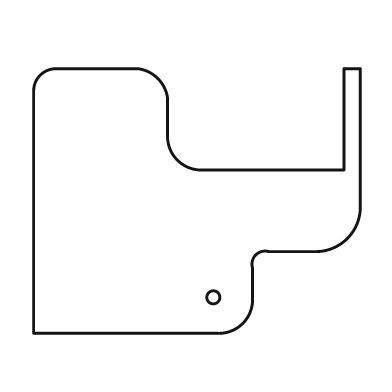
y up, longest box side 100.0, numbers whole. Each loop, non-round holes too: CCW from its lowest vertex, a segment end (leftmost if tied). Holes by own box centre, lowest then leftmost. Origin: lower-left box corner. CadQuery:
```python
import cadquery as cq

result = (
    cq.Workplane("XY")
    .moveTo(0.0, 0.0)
    .lineTo(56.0, 0.0)
    .threePointArc((64.0, 3.0), (67.0, 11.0))
    .lineTo(67.0, 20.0)
    .threePointArc((68.0, 24.0), (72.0, 25.0))
    .lineTo(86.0, 25.0)
    .threePointArc((96.0, 29.0), (100.0, 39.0))
    .lineTo(100.0, 81.0)
    .lineTo(95.0, 81.0)
    .lineTo(95.0, 50.0)
    .lineTo(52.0, 50.0)
    .threePointArc((44.0, 53.0), (41.0, 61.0))
    .lineTo(41.0, 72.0)
    .threePointArc((38.0, 78.0), (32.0, 81.0))
    .lineTo(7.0, 81.0)
    .threePointArc((2.0, 79.0), (0.0, 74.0))
    .close()
    .moveTo(55.0, 11.0)
    .circle(2.0)
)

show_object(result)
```